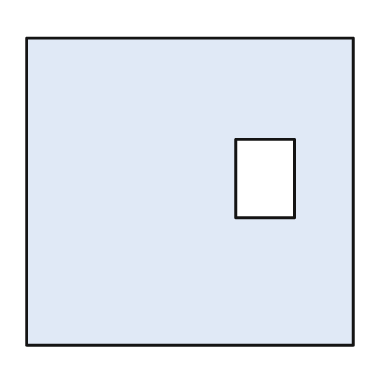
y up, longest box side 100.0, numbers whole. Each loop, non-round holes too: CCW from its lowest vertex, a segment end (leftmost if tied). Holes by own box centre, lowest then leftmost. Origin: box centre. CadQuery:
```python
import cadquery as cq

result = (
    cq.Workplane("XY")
    .moveTo(-50.0, -47.0)
    .lineTo(50.0, -47.0)
    .lineTo(50.0, 47.0)
    .lineTo(-50.0, 47.0)
    .close()
    .moveTo(14.0, -8.0)
    .lineTo(32.0, -8.0)
    .lineTo(32.0, 16.0)
    .lineTo(14.0, 16.0)
    .close()
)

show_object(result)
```